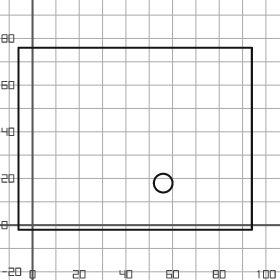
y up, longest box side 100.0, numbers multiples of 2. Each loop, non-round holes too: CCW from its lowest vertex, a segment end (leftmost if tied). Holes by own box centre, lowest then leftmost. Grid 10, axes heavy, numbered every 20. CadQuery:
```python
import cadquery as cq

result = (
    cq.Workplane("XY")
    .moveTo(-6.0, -2.0)
    .lineTo(94.0, -2.0)
    .lineTo(94.0, 76.0)
    .lineTo(-6.0, 76.0)
    .close()
    .moveTo(56.0, 18.0)
    .circle(4.0)
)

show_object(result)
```